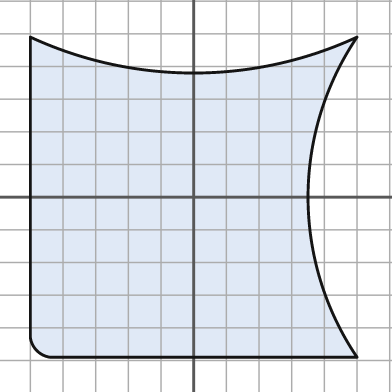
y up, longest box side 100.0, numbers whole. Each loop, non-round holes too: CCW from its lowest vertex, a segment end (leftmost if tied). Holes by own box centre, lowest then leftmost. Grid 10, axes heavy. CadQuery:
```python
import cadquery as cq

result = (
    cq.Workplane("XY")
    .moveTo(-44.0, -49.0)
    .lineTo(50.0, -49.0)
    .threePointArc((35.0, 0.0), (50.0, 49.0))
    .threePointArc((0.0, 38.0), (-50.0, 49.0))
    .lineTo(-50.0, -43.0)
    .threePointArc((-48.0, -47.0), (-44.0, -49.0))
    .close()
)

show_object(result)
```